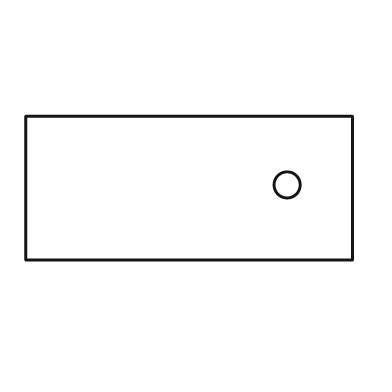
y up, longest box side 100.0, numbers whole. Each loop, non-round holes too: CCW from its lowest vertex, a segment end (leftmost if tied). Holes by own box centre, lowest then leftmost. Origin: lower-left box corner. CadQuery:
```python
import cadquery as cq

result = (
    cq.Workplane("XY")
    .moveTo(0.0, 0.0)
    .lineTo(100.0, 0.0)
    .lineTo(100.0, 44.0)
    .lineTo(0.0, 44.0)
    .close()
    .moveTo(80.0, 23.0)
    .circle(4.0)
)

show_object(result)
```